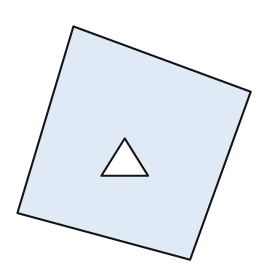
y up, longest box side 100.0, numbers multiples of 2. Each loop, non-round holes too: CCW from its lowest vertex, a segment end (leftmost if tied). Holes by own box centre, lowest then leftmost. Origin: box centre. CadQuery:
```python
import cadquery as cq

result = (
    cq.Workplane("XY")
    .moveTo(24.0, -50.0)
    .lineTo(50.0, 22.0)
    .lineTo(-26.0, 50.0)
    .lineTo(-50.0, -30.0)
    .close()
    .moveTo(-14.0, -14.0)
    .lineTo(6.0, -14.0)
    .lineTo(-4.0, 2.0)
    .close()
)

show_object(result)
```